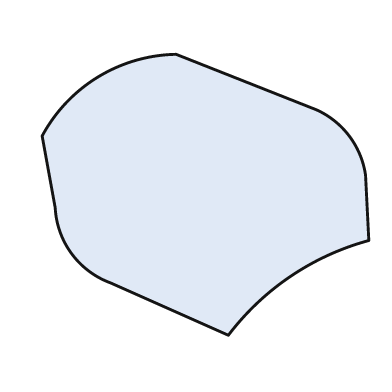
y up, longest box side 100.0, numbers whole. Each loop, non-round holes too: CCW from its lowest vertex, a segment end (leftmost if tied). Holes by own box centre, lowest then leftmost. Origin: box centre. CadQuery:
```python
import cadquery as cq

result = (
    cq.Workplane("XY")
    .moveTo(7.0, -43.0)
    .threePointArc((26.0, -25.0), (50.0, -14.0))
    .lineTo(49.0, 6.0)
    .threePointArc((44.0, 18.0), (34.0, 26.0))
    .lineTo(-9.0, 43.0)
    .threePointArc((-33.0, 36.0), (-50.0, 18.0))
    .lineTo(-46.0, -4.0)
    .threePointArc((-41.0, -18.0), (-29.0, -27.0))
    .close()
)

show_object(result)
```